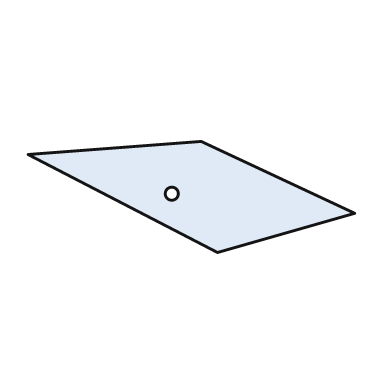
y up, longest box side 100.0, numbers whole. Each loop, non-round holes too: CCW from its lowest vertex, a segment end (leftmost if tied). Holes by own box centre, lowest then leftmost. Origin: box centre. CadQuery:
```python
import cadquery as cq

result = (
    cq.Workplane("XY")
    .moveTo(8.0, -17.0)
    .lineTo(50.0, -5.0)
    .lineTo(3.0, 17.0)
    .lineTo(-50.0, 13.0)
    .close()
    .moveTo(-6.0, 1.0)
    .circle(2.0)
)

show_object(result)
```